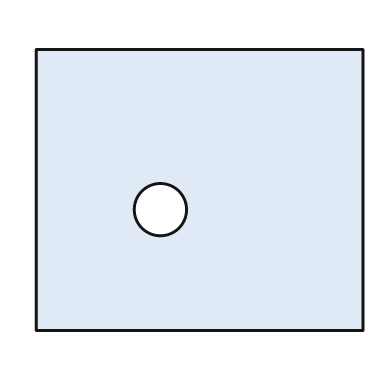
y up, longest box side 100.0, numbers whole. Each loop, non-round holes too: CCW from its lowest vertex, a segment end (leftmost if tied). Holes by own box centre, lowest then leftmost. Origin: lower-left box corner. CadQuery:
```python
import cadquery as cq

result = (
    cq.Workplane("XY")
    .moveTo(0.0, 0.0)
    .lineTo(100.0, 0.0)
    .lineTo(100.0, 86.0)
    .lineTo(0.0, 86.0)
    .close()
    .moveTo(38.0, 37.0)
    .circle(8.0)
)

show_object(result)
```